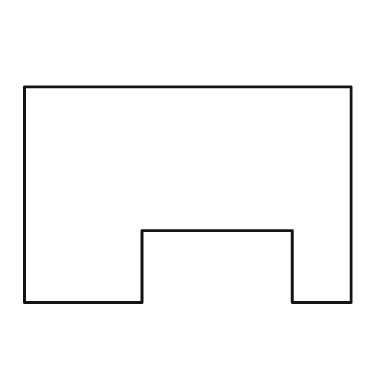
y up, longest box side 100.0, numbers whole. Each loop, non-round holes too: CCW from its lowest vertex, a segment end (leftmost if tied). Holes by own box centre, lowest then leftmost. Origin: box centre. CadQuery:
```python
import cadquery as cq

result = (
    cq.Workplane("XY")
    .moveTo(-50.0, -33.0)
    .lineTo(-14.0, -33.0)
    .lineTo(-14.0, -11.0)
    .lineTo(32.0, -11.0)
    .lineTo(32.0, -33.0)
    .lineTo(50.0, -33.0)
    .lineTo(50.0, 33.0)
    .lineTo(-50.0, 33.0)
    .close()
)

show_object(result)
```